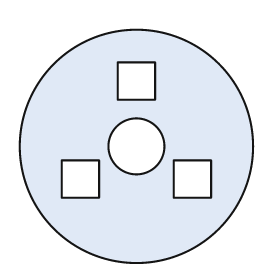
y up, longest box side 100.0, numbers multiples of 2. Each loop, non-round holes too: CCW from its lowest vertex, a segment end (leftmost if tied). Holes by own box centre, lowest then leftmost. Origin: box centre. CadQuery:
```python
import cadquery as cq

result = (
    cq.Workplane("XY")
    .moveTo(0.0, 0.0)
    .circle(50.0)
    .moveTo(-32.0, -22.0)
    .lineTo(-16.0, -22.0)
    .lineTo(-16.0, -6.0)
    .lineTo(-32.0, -6.0)
    .close()
    .moveTo(16.0, -22.0)
    .lineTo(32.0, -22.0)
    .lineTo(32.0, -6.0)
    .lineTo(16.0, -6.0)
    .close()
    .moveTo(0.0, 0.0)
    .circle(12.0)
    .moveTo(-8.0, 20.0)
    .lineTo(8.0, 20.0)
    .lineTo(8.0, 36.0)
    .lineTo(-8.0, 36.0)
    .close()
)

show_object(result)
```